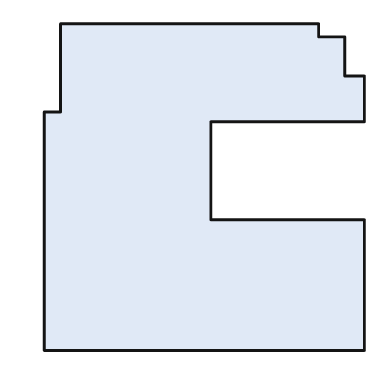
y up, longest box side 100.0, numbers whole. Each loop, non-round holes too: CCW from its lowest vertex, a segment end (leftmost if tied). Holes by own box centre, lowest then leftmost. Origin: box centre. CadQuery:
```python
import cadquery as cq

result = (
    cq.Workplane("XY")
    .moveTo(-49.0, -50.0)
    .lineTo(49.0, -50.0)
    .lineTo(49.0, -10.0)
    .lineTo(2.0, -10.0)
    .lineTo(2.0, 20.0)
    .lineTo(49.0, 20.0)
    .lineTo(49.0, 34.0)
    .lineTo(43.0, 34.0)
    .lineTo(43.0, 46.0)
    .lineTo(35.0, 46.0)
    .lineTo(35.0, 50.0)
    .lineTo(-44.0, 50.0)
    .lineTo(-44.0, 23.0)
    .lineTo(-49.0, 23.0)
    .close()
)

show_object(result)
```